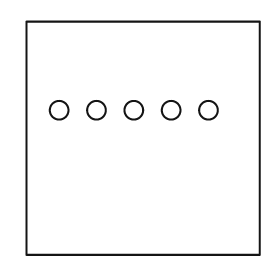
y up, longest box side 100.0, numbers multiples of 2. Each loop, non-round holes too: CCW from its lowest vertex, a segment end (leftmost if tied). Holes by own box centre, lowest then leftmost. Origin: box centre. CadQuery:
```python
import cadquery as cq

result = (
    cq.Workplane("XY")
    .moveTo(-50.0, -50.0)
    .lineTo(50.0, -50.0)
    .lineTo(50.0, 50.0)
    .lineTo(-50.0, 50.0)
    .close()
    .moveTo(-36.0, 12.0)
    .circle(4.0)
    .moveTo(-20.0, 12.0)
    .circle(4.0)
    .moveTo(-4.0, 12.0)
    .circle(4.0)
    .moveTo(12.0, 12.0)
    .circle(4.0)
    .moveTo(28.0, 12.0)
    .circle(4.0)
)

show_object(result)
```